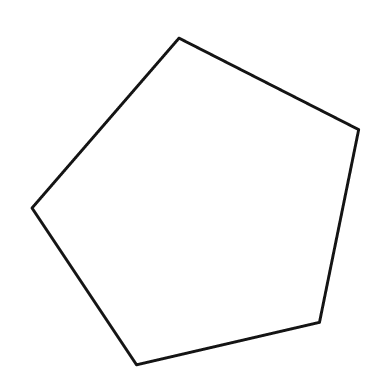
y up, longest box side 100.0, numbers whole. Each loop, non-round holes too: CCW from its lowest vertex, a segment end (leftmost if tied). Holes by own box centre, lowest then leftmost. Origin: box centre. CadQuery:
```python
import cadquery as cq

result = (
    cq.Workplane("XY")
    .moveTo(-18.0, -50.0)
    .lineTo(38.0, -37.0)
    .lineTo(50.0, 22.0)
    .lineTo(-5.0, 50.0)
    .lineTo(-50.0, -2.0)
    .close()
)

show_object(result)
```